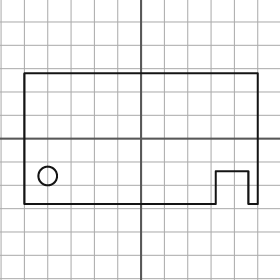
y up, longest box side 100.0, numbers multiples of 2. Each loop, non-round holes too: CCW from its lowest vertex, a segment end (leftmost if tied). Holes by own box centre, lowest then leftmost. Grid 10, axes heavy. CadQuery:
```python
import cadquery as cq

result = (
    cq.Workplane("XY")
    .moveTo(-50.0, -28.0)
    .lineTo(32.0, -28.0)
    .lineTo(32.0, -14.0)
    .lineTo(46.0, -14.0)
    .lineTo(46.0, -28.0)
    .lineTo(50.0, -28.0)
    .lineTo(50.0, 28.0)
    .lineTo(-50.0, 28.0)
    .close()
    .moveTo(-40.0, -16.0)
    .circle(4.0)
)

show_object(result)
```